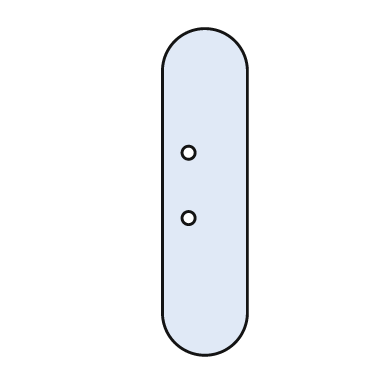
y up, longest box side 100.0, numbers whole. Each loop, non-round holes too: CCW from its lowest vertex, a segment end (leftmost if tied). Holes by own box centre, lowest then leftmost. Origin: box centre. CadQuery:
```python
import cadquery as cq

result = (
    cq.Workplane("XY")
    .moveTo(-13.0, -37.0)
    .threePointArc((0.0, -50.0), (13.0, -37.0))
    .lineTo(13.0, 37.0)
    .threePointArc((0.0, 50.0), (-13.0, 37.0))
    .close()
    .moveTo(-5.0, -8.0)
    .circle(2.0)
    .moveTo(-5.0, 12.0)
    .circle(2.0)
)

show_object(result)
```